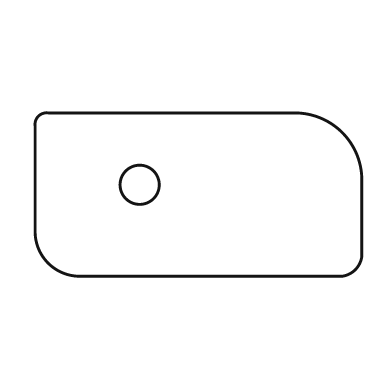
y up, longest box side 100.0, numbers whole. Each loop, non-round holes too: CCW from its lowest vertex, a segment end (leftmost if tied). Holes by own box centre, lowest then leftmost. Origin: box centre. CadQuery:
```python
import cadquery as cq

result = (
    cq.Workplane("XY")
    .moveTo(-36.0, -25.0)
    .lineTo(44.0, -25.0)
    .threePointArc((48.0, -23.0), (50.0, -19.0))
    .lineTo(50.0, 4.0)
    .threePointArc((44.0, 19.0), (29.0, 25.0))
    .lineTo(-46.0, 25.0)
    .threePointArc((-49.0, 24.0), (-50.0, 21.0))
    .lineTo(-50.0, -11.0)
    .threePointArc((-46.0, -21.0), (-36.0, -25.0))
    .close()
    .moveTo(-18.0, 3.0)
    .circle(6.0)
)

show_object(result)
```